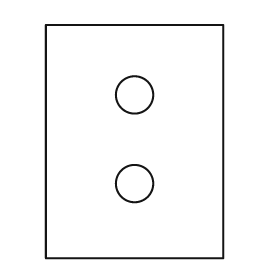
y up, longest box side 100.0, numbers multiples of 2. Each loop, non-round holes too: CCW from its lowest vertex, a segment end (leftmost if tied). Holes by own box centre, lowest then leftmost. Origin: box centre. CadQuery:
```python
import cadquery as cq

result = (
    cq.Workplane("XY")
    .moveTo(-38.0, -50.0)
    .lineTo(38.0, -50.0)
    .lineTo(38.0, 50.0)
    .lineTo(-38.0, 50.0)
    .close()
    .moveTo(0.0, -18.0)
    .circle(8.0)
    .moveTo(0.0, 20.0)
    .circle(8.0)
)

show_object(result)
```